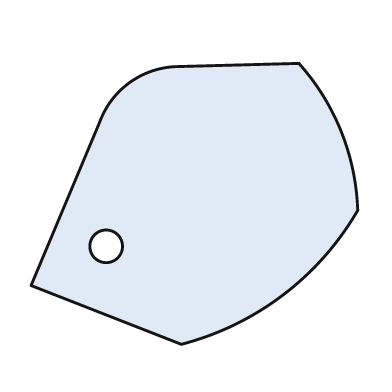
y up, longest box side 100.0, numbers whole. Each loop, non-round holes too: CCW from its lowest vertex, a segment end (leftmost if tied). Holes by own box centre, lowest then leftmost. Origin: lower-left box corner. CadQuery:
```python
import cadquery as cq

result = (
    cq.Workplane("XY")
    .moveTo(46.0, 0.0)
    .threePointArc((77.0, 15.0), (100.0, 41.0))
    .threePointArc((95.0, 65.0), (82.0, 86.0))
    .lineTo(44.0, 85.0)
    .threePointArc((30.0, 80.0), (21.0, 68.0))
    .lineTo(0.0, 18.0)
    .close()
    .moveTo(23.0, 30.0)
    .circle(5.0)
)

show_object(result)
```